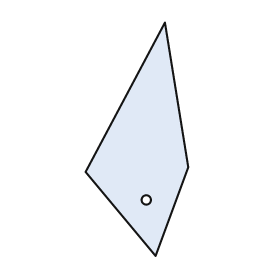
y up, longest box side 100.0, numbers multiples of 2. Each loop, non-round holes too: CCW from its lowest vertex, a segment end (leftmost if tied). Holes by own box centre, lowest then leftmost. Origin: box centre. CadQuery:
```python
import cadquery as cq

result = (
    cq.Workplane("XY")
    .moveTo(8.0, -50.0)
    .lineTo(22.0, -12.0)
    .lineTo(12.0, 50.0)
    .lineTo(-22.0, -14.0)
    .close()
    .moveTo(4.0, -26.0)
    .circle(2.0)
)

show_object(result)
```